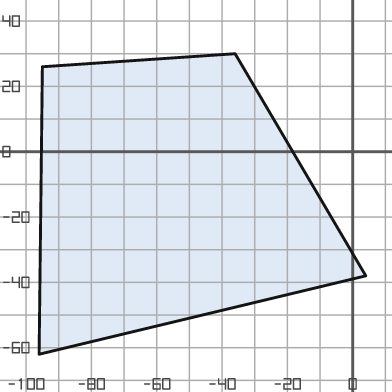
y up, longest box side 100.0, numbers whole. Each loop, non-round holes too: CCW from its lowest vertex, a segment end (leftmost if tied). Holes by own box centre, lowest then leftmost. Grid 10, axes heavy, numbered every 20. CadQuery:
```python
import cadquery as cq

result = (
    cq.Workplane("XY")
    .moveTo(-96.0, -62.0)
    .lineTo(4.0, -38.0)
    .lineTo(-36.0, 30.0)
    .lineTo(-95.0, 26.0)
    .close()
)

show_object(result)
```